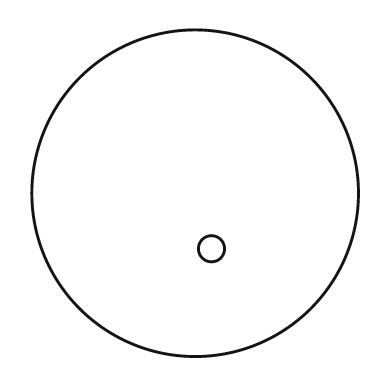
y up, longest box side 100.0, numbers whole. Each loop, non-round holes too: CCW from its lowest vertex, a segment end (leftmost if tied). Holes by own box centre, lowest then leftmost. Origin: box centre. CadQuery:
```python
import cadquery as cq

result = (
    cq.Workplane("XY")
    .moveTo(0.0, 0.0)
    .circle(50.0)
    .moveTo(5.0, -17.0)
    .circle(4.0)
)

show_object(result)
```